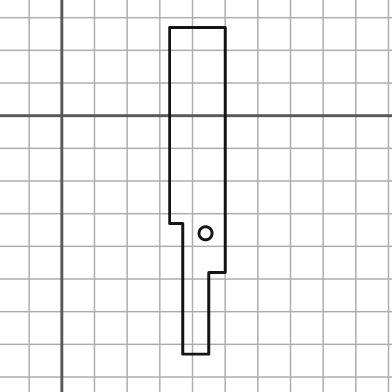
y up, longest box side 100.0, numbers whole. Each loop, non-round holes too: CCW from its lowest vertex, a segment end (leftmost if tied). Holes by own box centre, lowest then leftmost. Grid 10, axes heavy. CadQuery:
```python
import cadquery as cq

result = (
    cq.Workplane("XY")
    .moveTo(37.0, -73.0)
    .lineTo(45.0, -73.0)
    .lineTo(45.0, -48.0)
    .lineTo(50.0, -48.0)
    .lineTo(50.0, 27.0)
    .lineTo(33.0, 27.0)
    .lineTo(33.0, -33.0)
    .lineTo(37.0, -33.0)
    .close()
    .moveTo(44.0, -36.0)
    .circle(2.0)
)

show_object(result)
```